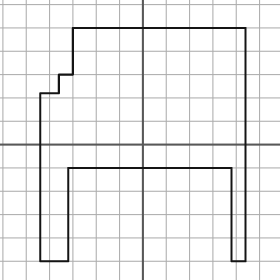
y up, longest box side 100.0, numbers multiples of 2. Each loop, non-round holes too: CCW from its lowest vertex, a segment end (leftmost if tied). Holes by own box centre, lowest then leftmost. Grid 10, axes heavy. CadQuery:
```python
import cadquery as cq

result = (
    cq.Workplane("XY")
    .moveTo(-44.0, -50.0)
    .lineTo(-32.0, -50.0)
    .lineTo(-32.0, -10.0)
    .lineTo(38.0, -10.0)
    .lineTo(38.0, -50.0)
    .lineTo(44.0, -50.0)
    .lineTo(44.0, 50.0)
    .lineTo(-30.0, 50.0)
    .lineTo(-30.0, 30.0)
    .lineTo(-36.0, 30.0)
    .lineTo(-36.0, 22.0)
    .lineTo(-44.0, 22.0)
    .close()
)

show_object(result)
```